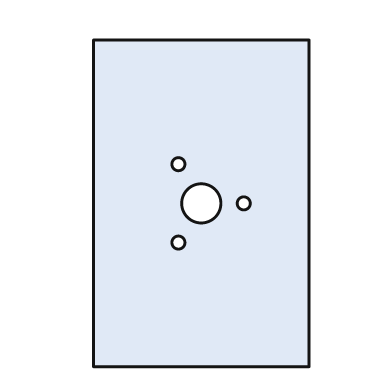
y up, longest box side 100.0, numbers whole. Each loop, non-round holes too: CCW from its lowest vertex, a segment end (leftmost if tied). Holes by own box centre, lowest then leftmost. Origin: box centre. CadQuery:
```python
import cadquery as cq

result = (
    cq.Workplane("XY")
    .moveTo(-33.0, -50.0)
    .lineTo(33.0, -50.0)
    .lineTo(33.0, 50.0)
    .lineTo(-33.0, 50.0)
    .close()
    .moveTo(-7.0, -12.0)
    .circle(2.0)
    .moveTo(0.0, 0.0)
    .circle(6.0)
    .moveTo(13.0, 0.0)
    .circle(2.0)
    .moveTo(-7.0, 12.0)
    .circle(2.0)
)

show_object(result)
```